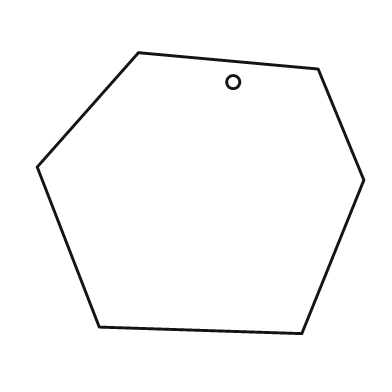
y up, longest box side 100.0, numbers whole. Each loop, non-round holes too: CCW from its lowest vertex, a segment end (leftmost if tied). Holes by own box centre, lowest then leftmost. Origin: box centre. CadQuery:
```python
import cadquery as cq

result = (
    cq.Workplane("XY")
    .moveTo(31.0, -43.0)
    .lineTo(50.0, 4.0)
    .lineTo(36.0, 38.0)
    .lineTo(-19.0, 43.0)
    .lineTo(-50.0, 8.0)
    .lineTo(-31.0, -41.0)
    .close()
    .moveTo(10.0, 34.0)
    .circle(2.0)
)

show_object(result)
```